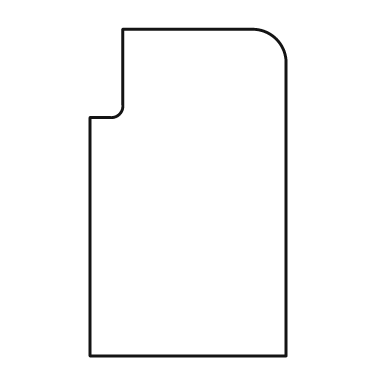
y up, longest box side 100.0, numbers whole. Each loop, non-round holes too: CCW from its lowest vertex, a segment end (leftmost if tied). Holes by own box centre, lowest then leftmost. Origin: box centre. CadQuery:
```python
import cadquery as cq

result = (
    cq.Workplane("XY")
    .moveTo(-30.0, -50.0)
    .lineTo(30.0, -50.0)
    .lineTo(30.0, 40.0)
    .threePointArc((27.0, 47.0), (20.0, 50.0))
    .lineTo(-20.0, 50.0)
    .lineTo(-20.0, 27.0)
    .threePointArc((-21.0, 24.0), (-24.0, 23.0))
    .lineTo(-30.0, 23.0)
    .close()
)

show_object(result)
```